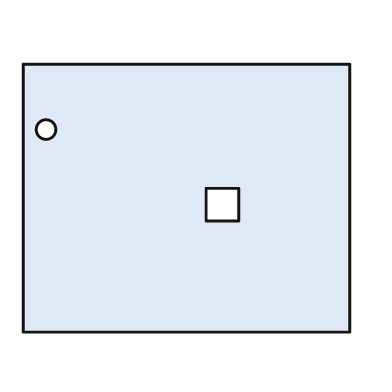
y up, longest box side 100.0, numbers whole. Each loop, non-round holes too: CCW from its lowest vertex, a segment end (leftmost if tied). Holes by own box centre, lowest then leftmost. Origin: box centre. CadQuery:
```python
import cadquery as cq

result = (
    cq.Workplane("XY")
    .moveTo(-50.0, -41.0)
    .lineTo(50.0, -41.0)
    .lineTo(50.0, 41.0)
    .lineTo(-50.0, 41.0)
    .close()
    .moveTo(6.0, -7.0)
    .lineTo(16.0, -7.0)
    .lineTo(16.0, 3.0)
    .lineTo(6.0, 3.0)
    .close()
    .moveTo(-43.0, 21.0)
    .circle(3.0)
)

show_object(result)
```